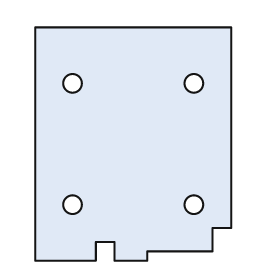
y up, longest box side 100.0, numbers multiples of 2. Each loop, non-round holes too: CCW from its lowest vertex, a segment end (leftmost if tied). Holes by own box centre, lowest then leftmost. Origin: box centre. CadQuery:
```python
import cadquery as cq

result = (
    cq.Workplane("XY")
    .moveTo(-42.0, -50.0)
    .lineTo(-16.0, -50.0)
    .lineTo(-16.0, -42.0)
    .lineTo(-8.0, -42.0)
    .lineTo(-8.0, -50.0)
    .lineTo(6.0, -50.0)
    .lineTo(6.0, -46.0)
    .lineTo(34.0, -46.0)
    .lineTo(34.0, -36.0)
    .lineTo(42.0, -36.0)
    .lineTo(42.0, 50.0)
    .lineTo(-42.0, 50.0)
    .close()
    .moveTo(-26.0, -26.0)
    .circle(4.0)
    .moveTo(26.0, -26.0)
    .circle(4.0)
    .moveTo(-26.0, 26.0)
    .circle(4.0)
    .moveTo(26.0, 26.0)
    .circle(4.0)
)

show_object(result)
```